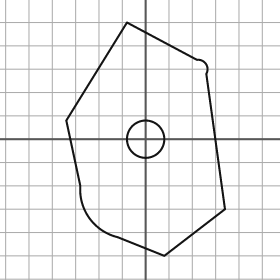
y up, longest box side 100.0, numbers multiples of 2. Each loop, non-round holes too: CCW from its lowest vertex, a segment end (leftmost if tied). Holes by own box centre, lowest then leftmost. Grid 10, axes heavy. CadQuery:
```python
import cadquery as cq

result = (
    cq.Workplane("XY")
    .moveTo(8.0, -50.0)
    .lineTo(34.0, -30.0)
    .lineTo(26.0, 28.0)
    .threePointArc((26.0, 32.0), (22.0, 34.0))
    .lineTo(-8.0, 50.0)
    .lineTo(-34.0, 8.0)
    .lineTo(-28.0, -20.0)
    .threePointArc((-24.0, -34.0), (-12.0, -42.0))
    .close()
    .moveTo(0.0, 0.0)
    .circle(8.0)
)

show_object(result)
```